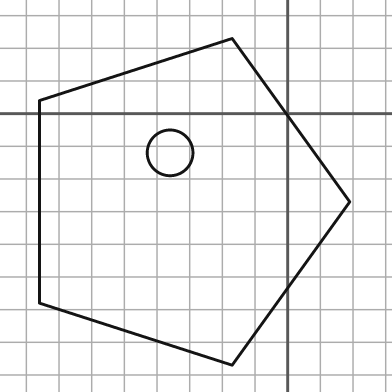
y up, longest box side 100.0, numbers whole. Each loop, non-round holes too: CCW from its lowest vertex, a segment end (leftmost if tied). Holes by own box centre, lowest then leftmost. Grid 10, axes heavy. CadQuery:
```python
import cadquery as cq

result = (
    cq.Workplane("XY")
    .moveTo(-17.0, -77.0)
    .lineTo(19.0, -27.0)
    .lineTo(-17.0, 23.0)
    .lineTo(-76.0, 4.0)
    .lineTo(-76.0, -58.0)
    .close()
    .moveTo(-36.0, -12.0)
    .circle(7.0)
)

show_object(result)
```